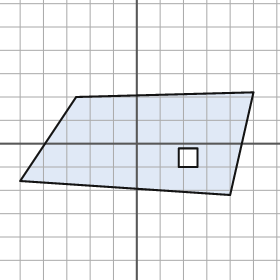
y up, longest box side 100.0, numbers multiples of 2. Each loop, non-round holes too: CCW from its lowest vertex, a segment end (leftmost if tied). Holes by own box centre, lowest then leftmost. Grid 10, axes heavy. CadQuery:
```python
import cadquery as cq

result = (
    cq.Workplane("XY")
    .moveTo(40.0, -22.0)
    .lineTo(50.0, 22.0)
    .lineTo(-26.0, 20.0)
    .lineTo(-50.0, -16.0)
    .close()
    .moveTo(18.0, -10.0)
    .lineTo(26.0, -10.0)
    .lineTo(26.0, -2.0)
    .lineTo(18.0, -2.0)
    .close()
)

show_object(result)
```